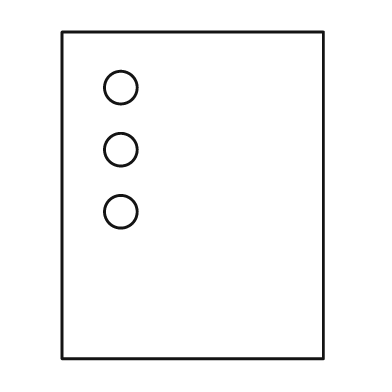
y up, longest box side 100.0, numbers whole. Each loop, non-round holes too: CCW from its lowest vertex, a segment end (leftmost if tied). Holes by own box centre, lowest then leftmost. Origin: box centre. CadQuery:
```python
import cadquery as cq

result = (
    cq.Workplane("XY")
    .moveTo(-40.0, -50.0)
    .lineTo(40.0, -50.0)
    .lineTo(40.0, 50.0)
    .lineTo(-40.0, 50.0)
    .close()
    .moveTo(-22.0, -5.0)
    .circle(5.0)
    .moveTo(-22.0, 14.0)
    .circle(5.0)
    .moveTo(-22.0, 33.0)
    .circle(5.0)
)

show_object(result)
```